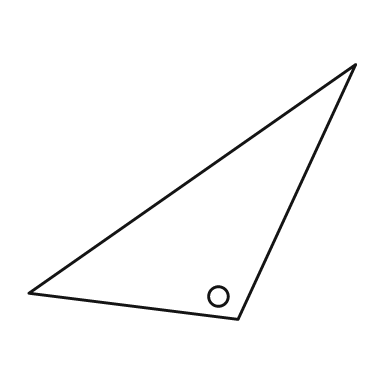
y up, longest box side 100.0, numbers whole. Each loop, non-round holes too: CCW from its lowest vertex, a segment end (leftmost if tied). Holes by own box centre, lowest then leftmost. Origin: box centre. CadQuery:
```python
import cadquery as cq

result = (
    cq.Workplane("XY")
    .moveTo(14.0, -39.0)
    .lineTo(50.0, 39.0)
    .lineTo(-50.0, -31.0)
    .close()
    .moveTo(8.0, -32.0)
    .circle(3.0)
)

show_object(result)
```